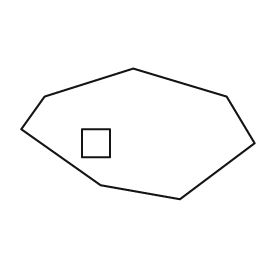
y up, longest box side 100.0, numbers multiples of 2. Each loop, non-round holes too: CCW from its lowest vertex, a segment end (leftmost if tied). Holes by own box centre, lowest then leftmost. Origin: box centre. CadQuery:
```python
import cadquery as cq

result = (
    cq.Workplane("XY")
    .moveTo(18.0, -28.0)
    .lineTo(50.0, -4.0)
    .lineTo(38.0, 16.0)
    .lineTo(-2.0, 28.0)
    .lineTo(-40.0, 16.0)
    .lineTo(-50.0, 2.0)
    .lineTo(-16.0, -22.0)
    .close()
    .moveTo(-24.0, -10.0)
    .lineTo(-12.0, -10.0)
    .lineTo(-12.0, 2.0)
    .lineTo(-24.0, 2.0)
    .close()
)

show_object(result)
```